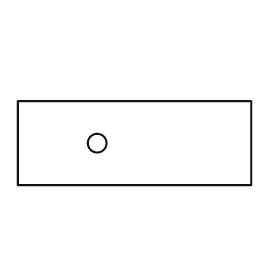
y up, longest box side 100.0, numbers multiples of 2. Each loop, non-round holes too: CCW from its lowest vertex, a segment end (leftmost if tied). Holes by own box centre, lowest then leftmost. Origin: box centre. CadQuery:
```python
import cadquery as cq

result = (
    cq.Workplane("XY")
    .moveTo(-50.0, -18.0)
    .lineTo(50.0, -18.0)
    .lineTo(50.0, 18.0)
    .lineTo(-50.0, 18.0)
    .close()
    .moveTo(-16.0, 0.0)
    .circle(4.0)
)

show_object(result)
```